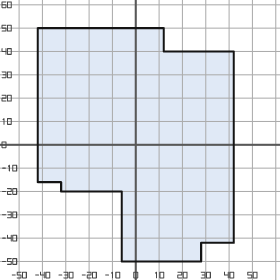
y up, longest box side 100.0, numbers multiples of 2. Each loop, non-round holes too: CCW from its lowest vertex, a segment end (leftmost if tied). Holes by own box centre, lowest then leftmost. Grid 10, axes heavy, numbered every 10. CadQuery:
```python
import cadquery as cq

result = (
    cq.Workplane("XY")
    .moveTo(-6.0, -50.0)
    .lineTo(28.0, -50.0)
    .lineTo(28.0, -42.0)
    .lineTo(42.0, -42.0)
    .lineTo(42.0, 40.0)
    .lineTo(12.0, 40.0)
    .lineTo(12.0, 50.0)
    .lineTo(-42.0, 50.0)
    .lineTo(-42.0, -16.0)
    .lineTo(-32.0, -16.0)
    .lineTo(-32.0, -20.0)
    .lineTo(-6.0, -20.0)
    .close()
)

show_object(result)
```